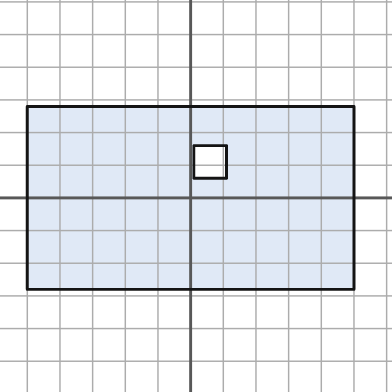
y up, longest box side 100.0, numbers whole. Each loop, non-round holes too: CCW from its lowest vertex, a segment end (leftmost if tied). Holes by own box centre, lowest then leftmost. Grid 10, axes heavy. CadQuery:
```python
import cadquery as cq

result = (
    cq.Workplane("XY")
    .moveTo(-50.0, -28.0)
    .lineTo(50.0, -28.0)
    .lineTo(50.0, 28.0)
    .lineTo(-50.0, 28.0)
    .close()
    .moveTo(1.0, 6.0)
    .lineTo(11.0, 6.0)
    .lineTo(11.0, 16.0)
    .lineTo(1.0, 16.0)
    .close()
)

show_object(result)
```